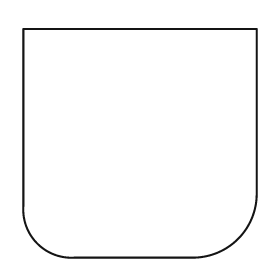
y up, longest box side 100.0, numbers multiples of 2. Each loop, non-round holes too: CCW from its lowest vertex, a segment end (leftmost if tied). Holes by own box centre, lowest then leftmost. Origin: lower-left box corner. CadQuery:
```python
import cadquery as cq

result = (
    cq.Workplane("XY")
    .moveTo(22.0, 0.0)
    .lineTo(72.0, 0.0)
    .threePointArc((92.0, 8.0), (100.0, 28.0))
    .lineTo(100.0, 98.0)
    .lineTo(0.0, 98.0)
    .lineTo(0.0, 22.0)
    .threePointArc((6.0, 6.0), (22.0, 0.0))
    .close()
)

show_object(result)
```